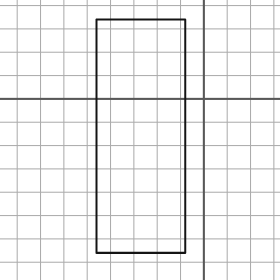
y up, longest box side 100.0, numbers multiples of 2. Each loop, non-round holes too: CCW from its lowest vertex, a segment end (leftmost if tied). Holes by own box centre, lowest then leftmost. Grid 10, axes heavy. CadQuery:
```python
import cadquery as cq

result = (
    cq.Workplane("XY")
    .moveTo(-46.0, -66.0)
    .lineTo(-8.0, -66.0)
    .lineTo(-8.0, 34.0)
    .lineTo(-46.0, 34.0)
    .close()
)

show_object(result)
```